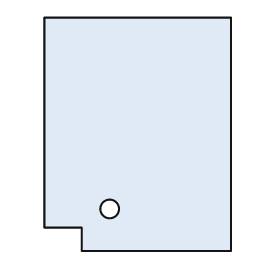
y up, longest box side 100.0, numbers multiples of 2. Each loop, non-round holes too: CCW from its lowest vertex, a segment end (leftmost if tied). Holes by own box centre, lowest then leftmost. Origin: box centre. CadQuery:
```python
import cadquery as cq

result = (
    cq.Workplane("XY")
    .moveTo(-24.0, -50.0)
    .lineTo(40.0, -50.0)
    .lineTo(40.0, 50.0)
    .lineTo(-40.0, 50.0)
    .lineTo(-40.0, -40.0)
    .lineTo(-24.0, -40.0)
    .close()
    .moveTo(-12.0, -32.0)
    .circle(4.0)
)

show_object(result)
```